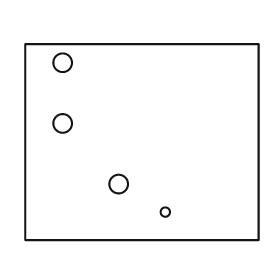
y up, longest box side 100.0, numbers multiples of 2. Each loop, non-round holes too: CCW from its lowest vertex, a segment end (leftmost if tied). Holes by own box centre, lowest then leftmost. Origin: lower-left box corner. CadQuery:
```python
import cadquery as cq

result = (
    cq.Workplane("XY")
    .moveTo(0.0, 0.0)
    .lineTo(100.0, 0.0)
    .lineTo(100.0, 84.0)
    .lineTo(0.0, 84.0)
    .close()
    .moveTo(60.0, 12.0)
    .circle(2.0)
    .moveTo(40.0, 24.0)
    .circle(4.0)
    .moveTo(16.0, 50.0)
    .circle(4.0)
    .moveTo(16.0, 76.0)
    .circle(4.0)
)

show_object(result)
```